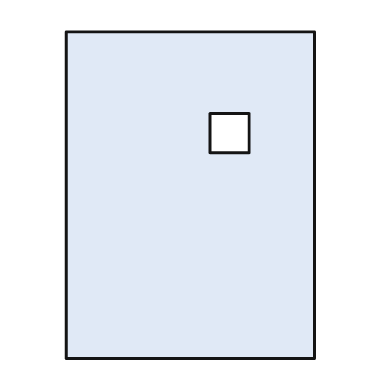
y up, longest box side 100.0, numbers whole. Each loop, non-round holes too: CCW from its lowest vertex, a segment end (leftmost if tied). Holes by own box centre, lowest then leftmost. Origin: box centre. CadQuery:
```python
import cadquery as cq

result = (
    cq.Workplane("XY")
    .moveTo(-38.0, -50.0)
    .lineTo(38.0, -50.0)
    .lineTo(38.0, 50.0)
    .lineTo(-38.0, 50.0)
    .close()
    .moveTo(6.0, 13.0)
    .lineTo(18.0, 13.0)
    .lineTo(18.0, 25.0)
    .lineTo(6.0, 25.0)
    .close()
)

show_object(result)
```